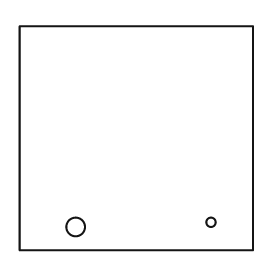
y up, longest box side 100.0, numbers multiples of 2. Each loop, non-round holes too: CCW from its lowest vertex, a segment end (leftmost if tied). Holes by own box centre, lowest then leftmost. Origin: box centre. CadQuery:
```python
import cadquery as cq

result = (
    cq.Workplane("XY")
    .moveTo(-50.0, -48.0)
    .lineTo(50.0, -48.0)
    .lineTo(50.0, 48.0)
    .lineTo(-50.0, 48.0)
    .close()
    .moveTo(-26.0, -38.0)
    .circle(4.0)
    .moveTo(32.0, -36.0)
    .circle(2.0)
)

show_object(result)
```